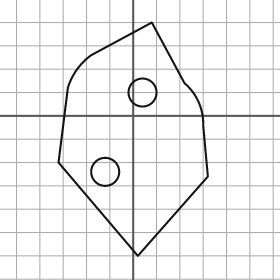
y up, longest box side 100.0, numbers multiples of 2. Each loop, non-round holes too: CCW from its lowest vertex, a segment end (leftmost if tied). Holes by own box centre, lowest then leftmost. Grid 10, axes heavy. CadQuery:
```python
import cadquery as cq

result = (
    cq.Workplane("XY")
    .moveTo(2.0, -60.0)
    .lineTo(32.0, -26.0)
    .lineTo(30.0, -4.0)
    .threePointArc((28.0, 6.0), (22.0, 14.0))
    .lineTo(8.0, 40.0)
    .lineTo(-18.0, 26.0)
    .threePointArc((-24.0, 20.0), (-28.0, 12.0))
    .lineTo(-32.0, -20.0)
    .close()
    .moveTo(-12.0, -24.0)
    .circle(6.0)
    .moveTo(4.0, 10.0)
    .circle(6.0)
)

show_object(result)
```